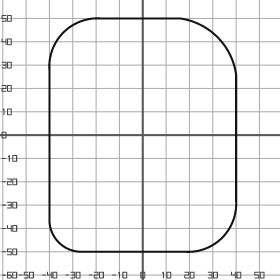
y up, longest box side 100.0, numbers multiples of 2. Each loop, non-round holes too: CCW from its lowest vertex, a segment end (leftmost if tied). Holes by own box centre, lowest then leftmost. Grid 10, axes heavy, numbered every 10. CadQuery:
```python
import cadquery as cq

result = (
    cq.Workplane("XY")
    .moveTo(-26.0, -50.0)
    .lineTo(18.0, -50.0)
    .threePointArc((34.0, -44.0), (40.0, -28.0))
    .lineTo(40.0, 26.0)
    .threePointArc((32.0, 42.0), (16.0, 50.0))
    .lineTo(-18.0, 50.0)
    .threePointArc((-34.0, 44.0), (-40.0, 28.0))
    .lineTo(-40.0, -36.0)
    .threePointArc((-36.0, -46.0), (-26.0, -50.0))
    .close()
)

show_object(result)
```